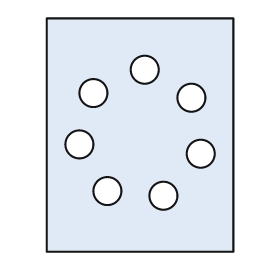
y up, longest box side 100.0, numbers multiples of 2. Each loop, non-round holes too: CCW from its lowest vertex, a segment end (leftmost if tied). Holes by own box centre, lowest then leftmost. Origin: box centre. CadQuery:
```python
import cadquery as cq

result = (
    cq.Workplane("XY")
    .moveTo(-40.0, -50.0)
    .lineTo(40.0, -50.0)
    .lineTo(40.0, 50.0)
    .lineTo(-40.0, 50.0)
    .close()
    .moveTo(10.0, -26.0)
    .circle(6.0)
    .moveTo(-14.0, -24.0)
    .circle(6.0)
    .moveTo(26.0, -8.0)
    .circle(6.0)
    .moveTo(-26.0, -4.0)
    .circle(6.0)
    .moveTo(22.0, 16.0)
    .circle(6.0)
    .moveTo(-20.0, 18.0)
    .circle(6.0)
    .moveTo(2.0, 28.0)
    .circle(6.0)
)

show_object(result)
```